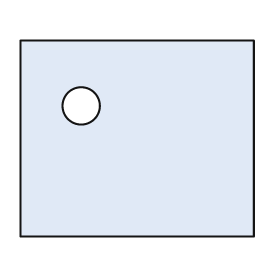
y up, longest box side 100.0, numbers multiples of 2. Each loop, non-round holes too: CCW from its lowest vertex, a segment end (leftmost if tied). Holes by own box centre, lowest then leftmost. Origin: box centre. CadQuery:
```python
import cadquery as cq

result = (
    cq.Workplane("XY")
    .moveTo(-50.0, -42.0)
    .lineTo(50.0, -42.0)
    .lineTo(50.0, 42.0)
    .lineTo(-50.0, 42.0)
    .close()
    .moveTo(-24.0, 14.0)
    .circle(8.0)
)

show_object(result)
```